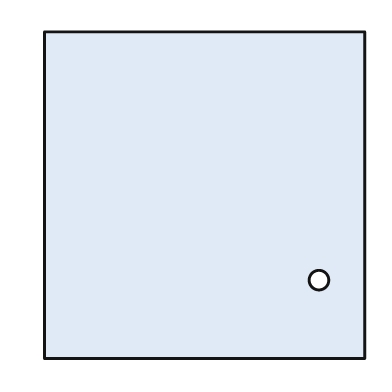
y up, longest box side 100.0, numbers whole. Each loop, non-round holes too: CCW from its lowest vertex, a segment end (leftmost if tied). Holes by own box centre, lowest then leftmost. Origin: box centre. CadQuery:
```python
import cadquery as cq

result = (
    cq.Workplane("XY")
    .moveTo(-49.0, -50.0)
    .lineTo(49.0, -50.0)
    .lineTo(49.0, 50.0)
    .lineTo(-49.0, 50.0)
    .close()
    .moveTo(35.0, -26.0)
    .circle(3.0)
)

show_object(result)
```